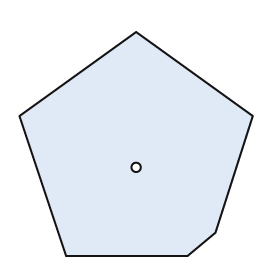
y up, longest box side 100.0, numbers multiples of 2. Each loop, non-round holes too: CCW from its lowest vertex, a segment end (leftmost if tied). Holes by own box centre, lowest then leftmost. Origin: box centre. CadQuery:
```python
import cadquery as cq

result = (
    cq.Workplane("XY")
    .moveTo(-30.0, -48.0)
    .lineTo(22.0, -48.0)
    .lineTo(34.0, -38.0)
    .lineTo(50.0, 12.0)
    .lineTo(0.0, 48.0)
    .lineTo(-50.0, 12.0)
    .close()
    .moveTo(0.0, -10.0)
    .circle(2.0)
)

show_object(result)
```